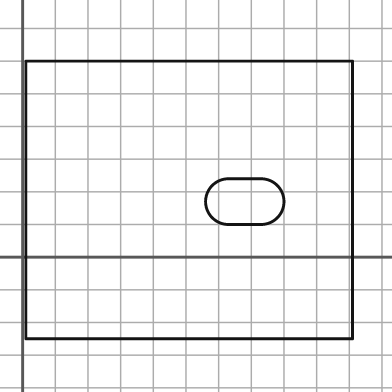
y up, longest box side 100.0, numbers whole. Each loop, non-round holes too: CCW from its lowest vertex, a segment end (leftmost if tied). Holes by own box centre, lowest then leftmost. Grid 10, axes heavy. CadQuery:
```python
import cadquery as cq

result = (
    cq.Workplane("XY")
    .moveTo(1.0, -25.0)
    .lineTo(101.0, -25.0)
    .lineTo(101.0, 60.0)
    .lineTo(1.0, 60.0)
    .close()
    .moveTo(63.0, 10.0)
    .lineTo(73.0, 10.0)
    .threePointArc((80.0, 17.0), (73.0, 24.0))
    .lineTo(63.0, 24.0)
    .threePointArc((56.0, 17.0), (63.0, 10.0))
    .close()
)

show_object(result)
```